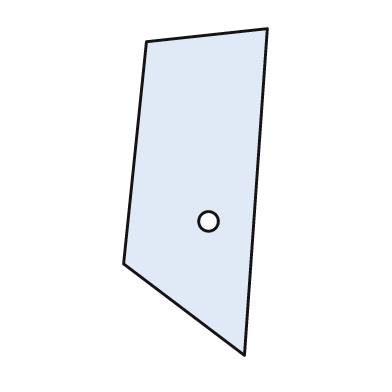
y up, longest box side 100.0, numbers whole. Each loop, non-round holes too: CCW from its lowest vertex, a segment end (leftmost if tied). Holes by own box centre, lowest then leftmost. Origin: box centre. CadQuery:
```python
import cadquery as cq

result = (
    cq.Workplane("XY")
    .moveTo(15.0, -50.0)
    .lineTo(22.0, 50.0)
    .lineTo(-15.0, 46.0)
    .lineTo(-22.0, -22.0)
    .close()
    .moveTo(4.0, -9.0)
    .circle(3.0)
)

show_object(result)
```